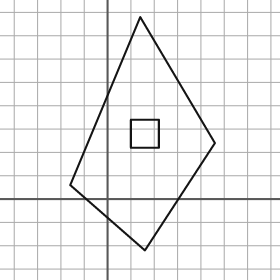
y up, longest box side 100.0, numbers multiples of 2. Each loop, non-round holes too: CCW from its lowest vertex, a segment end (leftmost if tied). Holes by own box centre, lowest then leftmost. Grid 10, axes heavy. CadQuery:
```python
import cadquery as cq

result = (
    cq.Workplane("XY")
    .moveTo(16.0, -22.0)
    .lineTo(46.0, 24.0)
    .lineTo(14.0, 78.0)
    .lineTo(-16.0, 6.0)
    .close()
    .moveTo(10.0, 22.0)
    .lineTo(22.0, 22.0)
    .lineTo(22.0, 34.0)
    .lineTo(10.0, 34.0)
    .close()
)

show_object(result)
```